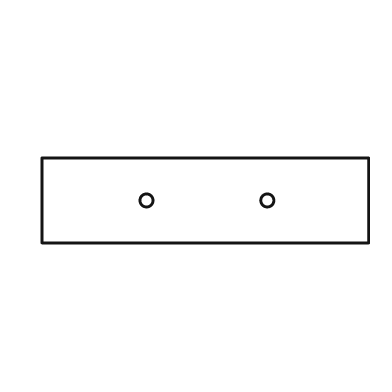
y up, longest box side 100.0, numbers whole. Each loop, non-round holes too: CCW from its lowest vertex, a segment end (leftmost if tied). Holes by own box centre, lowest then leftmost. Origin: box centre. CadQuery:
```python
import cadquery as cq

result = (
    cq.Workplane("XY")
    .moveTo(-50.0, -13.0)
    .lineTo(50.0, -13.0)
    .lineTo(50.0, 13.0)
    .lineTo(-50.0, 13.0)
    .close()
    .moveTo(-18.0, 0.0)
    .circle(2.0)
    .moveTo(19.0, 0.0)
    .circle(2.0)
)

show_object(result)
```